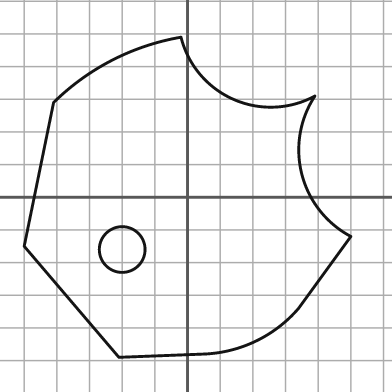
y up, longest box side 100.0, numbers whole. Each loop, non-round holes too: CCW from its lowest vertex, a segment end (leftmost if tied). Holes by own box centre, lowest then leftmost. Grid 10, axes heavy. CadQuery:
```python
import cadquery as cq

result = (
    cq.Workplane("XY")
    .moveTo(-21.0, -49.0)
    .lineTo(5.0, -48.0)
    .threePointArc((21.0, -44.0), (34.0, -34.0))
    .lineTo(50.0, -12.0)
    .threePointArc((35.0, 7.0), (39.0, 31.0))
    .threePointArc((14.0, 30.0), (-2.0, 49.0))
    .threePointArc((-23.0, 42.0), (-41.0, 29.0))
    .lineTo(-50.0, -15.0)
    .close()
    .moveTo(-20.0, -16.0)
    .circle(7.0)
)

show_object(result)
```